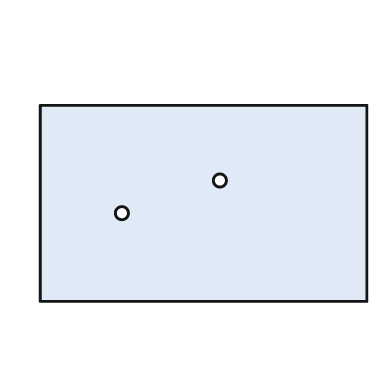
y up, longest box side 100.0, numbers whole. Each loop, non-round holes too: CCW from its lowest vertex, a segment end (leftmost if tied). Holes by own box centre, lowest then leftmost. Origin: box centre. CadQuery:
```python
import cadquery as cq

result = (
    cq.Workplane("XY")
    .moveTo(-50.0, -30.0)
    .lineTo(50.0, -30.0)
    .lineTo(50.0, 30.0)
    .lineTo(-50.0, 30.0)
    .close()
    .moveTo(-25.0, -3.0)
    .circle(2.0)
    .moveTo(5.0, 7.0)
    .circle(2.0)
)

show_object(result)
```